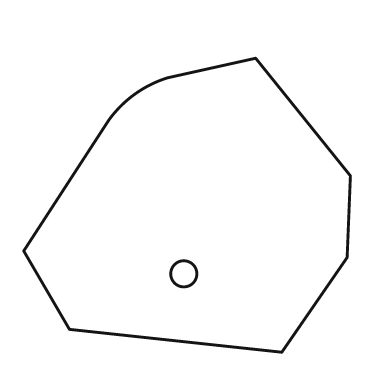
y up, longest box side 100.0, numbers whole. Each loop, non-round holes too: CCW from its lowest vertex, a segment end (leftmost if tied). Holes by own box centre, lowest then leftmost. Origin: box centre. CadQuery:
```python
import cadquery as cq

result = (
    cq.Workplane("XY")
    .moveTo(29.0, -45.0)
    .lineTo(49.0, -16.0)
    .lineTo(50.0, 9.0)
    .lineTo(21.0, 45.0)
    .lineTo(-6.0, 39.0)
    .threePointArc((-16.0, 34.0), (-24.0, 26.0))
    .lineTo(-50.0, -14.0)
    .lineTo(-36.0, -38.0)
    .close()
    .moveTo(-1.0, -21.0)
    .circle(4.0)
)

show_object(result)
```